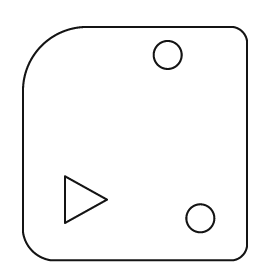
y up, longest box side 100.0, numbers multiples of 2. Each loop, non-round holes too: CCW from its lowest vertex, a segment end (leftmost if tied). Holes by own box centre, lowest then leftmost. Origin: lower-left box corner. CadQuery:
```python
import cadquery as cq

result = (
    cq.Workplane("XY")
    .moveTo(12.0, 0.0)
    .lineTo(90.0, 0.0)
    .threePointArc((94.0, 2.0), (96.0, 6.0))
    .lineTo(96.0, 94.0)
    .threePointArc((94.0, 98.0), (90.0, 100.0))
    .lineTo(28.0, 100.0)
    .threePointArc((8.0, 92.0), (0.0, 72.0))
    .lineTo(0.0, 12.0)
    .threePointArc((4.0, 4.0), (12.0, 0.0))
    .close()
    .moveTo(76.0, 18.0)
    .circle(6.0)
    .moveTo(18.0, 16.0)
    .lineTo(36.0, 26.0)
    .lineTo(18.0, 36.0)
    .close()
    .moveTo(62.0, 88.0)
    .circle(6.0)
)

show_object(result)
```